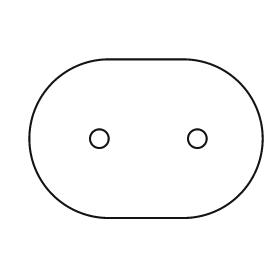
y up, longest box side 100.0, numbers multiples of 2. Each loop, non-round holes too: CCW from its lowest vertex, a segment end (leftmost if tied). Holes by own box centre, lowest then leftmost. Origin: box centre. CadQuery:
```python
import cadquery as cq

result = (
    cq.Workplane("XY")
    .moveTo(-16.0, -34.0)
    .lineTo(16.0, -34.0)
    .threePointArc((50.0, 0.0), (16.0, 34.0))
    .lineTo(-16.0, 34.0)
    .threePointArc((-50.0, 0.0), (-16.0, -34.0))
    .close()
    .moveTo(-20.0, 0.0)
    .circle(4.0)
    .moveTo(22.0, 0.0)
    .circle(4.0)
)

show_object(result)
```